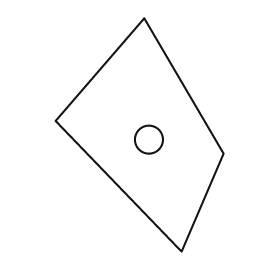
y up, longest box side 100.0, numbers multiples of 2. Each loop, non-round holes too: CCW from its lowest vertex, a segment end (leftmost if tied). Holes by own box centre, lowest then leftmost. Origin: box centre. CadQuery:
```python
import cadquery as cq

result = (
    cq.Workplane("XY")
    .moveTo(18.0, -50.0)
    .lineTo(36.0, -8.0)
    .lineTo(2.0, 50.0)
    .lineTo(-36.0, 6.0)
    .close()
    .moveTo(4.0, -2.0)
    .circle(6.0)
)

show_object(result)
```